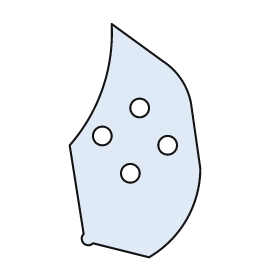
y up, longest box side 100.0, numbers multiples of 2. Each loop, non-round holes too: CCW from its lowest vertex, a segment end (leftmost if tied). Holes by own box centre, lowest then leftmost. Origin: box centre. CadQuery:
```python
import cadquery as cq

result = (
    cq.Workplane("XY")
    .moveTo(6.0, -50.0)
    .threePointArc((22.0, -34.0), (28.0, -12.0))
    .lineTo(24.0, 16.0)
    .threePointArc((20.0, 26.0), (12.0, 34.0))
    .lineTo(-10.0, 50.0)
    .threePointArc((-14.0, 22.0), (-28.0, -2.0))
    .lineTo(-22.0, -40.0)
    .threePointArc((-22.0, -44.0), (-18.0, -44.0))
    .close()
    .moveTo(-2.0, -14.0)
    .circle(4.0)
    .moveTo(14.0, -2.0)
    .circle(4.0)
    .moveTo(-14.0, 2.0)
    .circle(4.0)
    .moveTo(2.0, 14.0)
    .circle(4.0)
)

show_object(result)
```